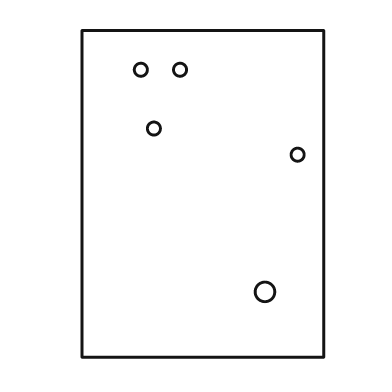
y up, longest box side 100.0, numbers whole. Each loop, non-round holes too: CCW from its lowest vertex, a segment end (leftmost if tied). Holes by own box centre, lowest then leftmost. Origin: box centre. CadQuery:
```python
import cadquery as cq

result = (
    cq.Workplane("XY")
    .moveTo(-37.0, -50.0)
    .lineTo(37.0, -50.0)
    .lineTo(37.0, 50.0)
    .lineTo(-37.0, 50.0)
    .close()
    .moveTo(19.0, -30.0)
    .circle(3.0)
    .moveTo(29.0, 12.0)
    .circle(2.0)
    .moveTo(-15.0, 20.0)
    .circle(2.0)
    .moveTo(-19.0, 38.0)
    .circle(2.0)
    .moveTo(-7.0, 38.0)
    .circle(2.0)
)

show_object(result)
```